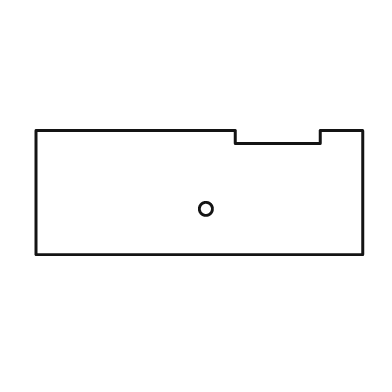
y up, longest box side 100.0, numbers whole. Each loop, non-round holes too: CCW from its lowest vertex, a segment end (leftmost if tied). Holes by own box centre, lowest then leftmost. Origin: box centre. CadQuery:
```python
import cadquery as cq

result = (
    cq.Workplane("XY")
    .moveTo(-50.0, -19.0)
    .lineTo(50.0, -19.0)
    .lineTo(50.0, 19.0)
    .lineTo(37.0, 19.0)
    .lineTo(37.0, 15.0)
    .lineTo(11.0, 15.0)
    .lineTo(11.0, 19.0)
    .lineTo(-50.0, 19.0)
    .close()
    .moveTo(2.0, -5.0)
    .circle(2.0)
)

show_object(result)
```